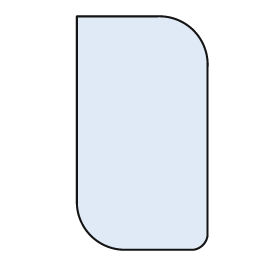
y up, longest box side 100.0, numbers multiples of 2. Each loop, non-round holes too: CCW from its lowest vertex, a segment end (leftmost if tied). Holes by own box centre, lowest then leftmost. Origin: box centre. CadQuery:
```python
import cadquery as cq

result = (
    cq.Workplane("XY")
    .moveTo(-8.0, -50.0)
    .lineTo(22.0, -50.0)
    .threePointArc((26.0, -48.0), (28.0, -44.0))
    .lineTo(28.0, 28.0)
    .threePointArc((22.0, 44.0), (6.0, 50.0))
    .lineTo(-28.0, 50.0)
    .lineTo(-28.0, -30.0)
    .threePointArc((-22.0, -44.0), (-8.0, -50.0))
    .close()
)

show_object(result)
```